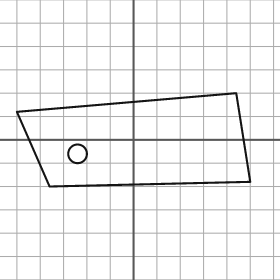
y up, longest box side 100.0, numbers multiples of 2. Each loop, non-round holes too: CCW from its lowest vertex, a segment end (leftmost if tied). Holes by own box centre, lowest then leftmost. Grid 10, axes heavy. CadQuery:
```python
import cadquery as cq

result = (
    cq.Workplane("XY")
    .moveTo(-36.0, -20.0)
    .lineTo(50.0, -18.0)
    .lineTo(44.0, 20.0)
    .lineTo(-50.0, 12.0)
    .close()
    .moveTo(-24.0, -6.0)
    .circle(4.0)
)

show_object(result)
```